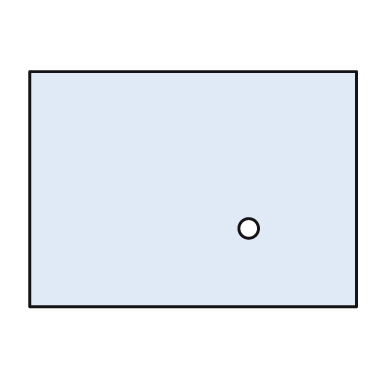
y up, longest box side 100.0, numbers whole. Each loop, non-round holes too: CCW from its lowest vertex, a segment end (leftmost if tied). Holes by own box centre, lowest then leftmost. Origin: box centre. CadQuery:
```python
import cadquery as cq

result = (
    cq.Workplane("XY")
    .moveTo(-50.0, -36.0)
    .lineTo(50.0, -36.0)
    .lineTo(50.0, 36.0)
    .lineTo(-50.0, 36.0)
    .close()
    .moveTo(17.0, -12.0)
    .circle(3.0)
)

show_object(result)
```